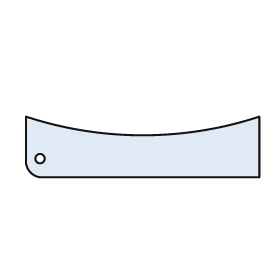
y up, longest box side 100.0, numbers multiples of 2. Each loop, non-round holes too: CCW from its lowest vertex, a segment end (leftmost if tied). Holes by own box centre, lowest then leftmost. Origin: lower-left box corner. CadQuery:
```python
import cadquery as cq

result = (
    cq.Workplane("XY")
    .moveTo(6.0, 0.0)
    .lineTo(100.0, 0.0)
    .lineTo(100.0, 26.0)
    .threePointArc((50.0, 18.0), (0.0, 26.0))
    .lineTo(0.0, 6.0)
    .threePointArc((2.0, 2.0), (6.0, 0.0))
    .close()
    .moveTo(6.0, 8.0)
    .circle(2.0)
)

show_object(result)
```